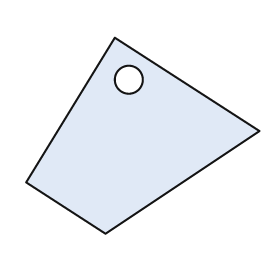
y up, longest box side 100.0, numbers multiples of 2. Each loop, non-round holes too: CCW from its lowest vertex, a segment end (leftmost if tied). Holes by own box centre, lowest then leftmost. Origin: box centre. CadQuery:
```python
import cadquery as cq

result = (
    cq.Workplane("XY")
    .moveTo(-16.0, -42.0)
    .lineTo(50.0, 2.0)
    .lineTo(-12.0, 42.0)
    .lineTo(-50.0, -20.0)
    .close()
    .moveTo(-6.0, 24.0)
    .circle(6.0)
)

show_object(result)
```